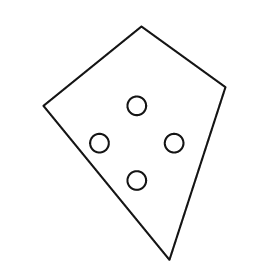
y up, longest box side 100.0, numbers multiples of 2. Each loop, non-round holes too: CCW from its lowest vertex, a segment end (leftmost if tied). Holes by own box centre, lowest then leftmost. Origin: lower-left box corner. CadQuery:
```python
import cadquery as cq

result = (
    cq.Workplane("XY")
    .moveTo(54.0, 0.0)
    .lineTo(78.0, 74.0)
    .lineTo(42.0, 100.0)
    .lineTo(0.0, 66.0)
    .close()
    .moveTo(40.0, 34.0)
    .circle(4.0)
    .moveTo(24.0, 50.0)
    .circle(4.0)
    .moveTo(56.0, 50.0)
    .circle(4.0)
    .moveTo(40.0, 66.0)
    .circle(4.0)
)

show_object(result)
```